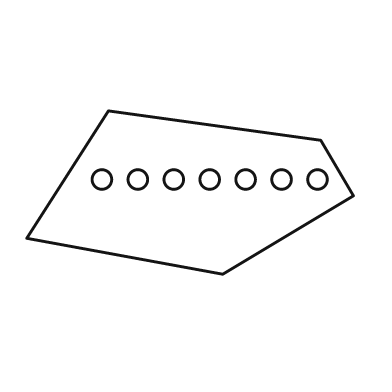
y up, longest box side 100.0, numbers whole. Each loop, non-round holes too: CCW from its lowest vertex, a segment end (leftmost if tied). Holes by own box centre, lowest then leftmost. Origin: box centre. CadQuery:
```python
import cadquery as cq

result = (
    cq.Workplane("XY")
    .moveTo(10.0, -25.0)
    .lineTo(50.0, -1.0)
    .lineTo(40.0, 16.0)
    .lineTo(-25.0, 25.0)
    .lineTo(-50.0, -14.0)
    .close()
    .moveTo(-27.0, 4.0)
    .circle(3.0)
    .moveTo(-16.0, 4.0)
    .circle(3.0)
    .moveTo(-5.0, 4.0)
    .circle(3.0)
    .moveTo(6.0, 4.0)
    .circle(3.0)
    .moveTo(17.0, 4.0)
    .circle(3.0)
    .moveTo(28.0, 4.0)
    .circle(3.0)
    .moveTo(39.0, 4.0)
    .circle(3.0)
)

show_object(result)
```